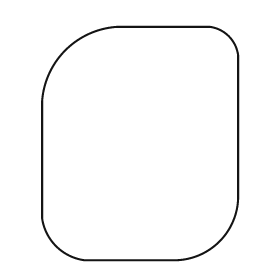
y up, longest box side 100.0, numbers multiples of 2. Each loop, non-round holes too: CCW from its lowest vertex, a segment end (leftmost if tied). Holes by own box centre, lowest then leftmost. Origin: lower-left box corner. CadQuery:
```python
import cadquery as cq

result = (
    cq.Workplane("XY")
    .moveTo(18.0, 0.0)
    .lineTo(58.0, 0.0)
    .threePointArc((76.0, 8.0), (84.0, 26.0))
    .lineTo(84.0, 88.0)
    .threePointArc((80.0, 96.0), (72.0, 100.0))
    .lineTo(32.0, 100.0)
    .threePointArc((10.0, 90.0), (0.0, 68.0))
    .lineTo(0.0, 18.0)
    .threePointArc((6.0, 6.0), (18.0, 0.0))
    .close()
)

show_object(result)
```